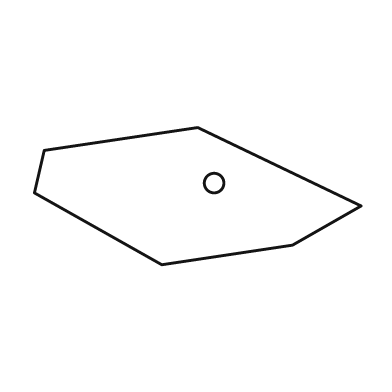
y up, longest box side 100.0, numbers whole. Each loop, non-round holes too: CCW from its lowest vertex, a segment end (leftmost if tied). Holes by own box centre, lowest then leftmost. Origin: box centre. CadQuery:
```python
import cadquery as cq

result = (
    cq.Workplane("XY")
    .moveTo(-11.0, -21.0)
    .lineTo(29.0, -15.0)
    .lineTo(50.0, -3.0)
    .lineTo(0.0, 21.0)
    .lineTo(-47.0, 14.0)
    .lineTo(-50.0, 1.0)
    .close()
    .moveTo(5.0, 4.0)
    .circle(3.0)
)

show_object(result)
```